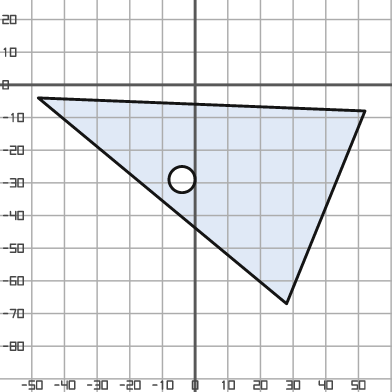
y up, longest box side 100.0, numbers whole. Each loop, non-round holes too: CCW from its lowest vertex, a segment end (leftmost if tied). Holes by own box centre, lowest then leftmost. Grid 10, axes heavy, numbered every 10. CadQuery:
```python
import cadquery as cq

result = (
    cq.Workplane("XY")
    .moveTo(28.0, -67.0)
    .lineTo(52.0, -8.0)
    .lineTo(-48.0, -4.0)
    .close()
    .moveTo(-4.0, -29.0)
    .circle(4.0)
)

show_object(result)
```